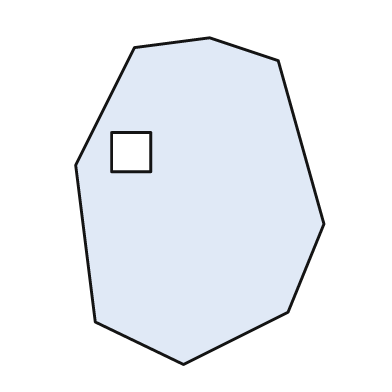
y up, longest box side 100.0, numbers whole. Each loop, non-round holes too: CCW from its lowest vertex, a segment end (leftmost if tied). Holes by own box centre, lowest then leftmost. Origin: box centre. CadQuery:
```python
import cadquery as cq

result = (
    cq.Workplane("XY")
    .moveTo(-5.0, -50.0)
    .lineTo(27.0, -34.0)
    .lineTo(38.0, -7.0)
    .lineTo(24.0, 43.0)
    .lineTo(3.0, 50.0)
    .lineTo(-20.0, 47.0)
    .lineTo(-38.0, 11.0)
    .lineTo(-32.0, -37.0)
    .close()
    .moveTo(-27.0, 9.0)
    .lineTo(-15.0, 9.0)
    .lineTo(-15.0, 21.0)
    .lineTo(-27.0, 21.0)
    .close()
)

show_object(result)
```